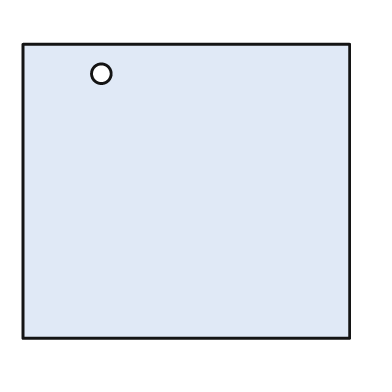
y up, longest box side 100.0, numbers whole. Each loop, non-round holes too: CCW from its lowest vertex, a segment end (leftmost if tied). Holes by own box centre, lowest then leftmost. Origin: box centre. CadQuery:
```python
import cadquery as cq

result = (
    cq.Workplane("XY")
    .moveTo(-50.0, -45.0)
    .lineTo(50.0, -45.0)
    .lineTo(50.0, 45.0)
    .lineTo(-50.0, 45.0)
    .close()
    .moveTo(-26.0, 36.0)
    .circle(3.0)
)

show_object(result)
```